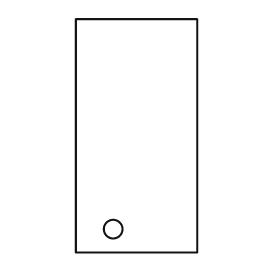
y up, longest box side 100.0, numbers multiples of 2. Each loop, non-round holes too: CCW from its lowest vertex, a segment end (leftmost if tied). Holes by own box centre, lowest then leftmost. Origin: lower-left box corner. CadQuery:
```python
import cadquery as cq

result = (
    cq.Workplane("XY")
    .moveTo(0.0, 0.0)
    .lineTo(52.0, 0.0)
    .lineTo(52.0, 100.0)
    .lineTo(0.0, 100.0)
    .close()
    .moveTo(16.0, 10.0)
    .circle(4.0)
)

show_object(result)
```